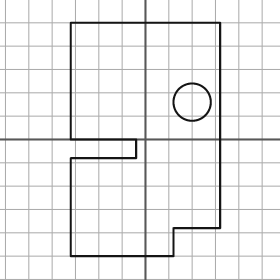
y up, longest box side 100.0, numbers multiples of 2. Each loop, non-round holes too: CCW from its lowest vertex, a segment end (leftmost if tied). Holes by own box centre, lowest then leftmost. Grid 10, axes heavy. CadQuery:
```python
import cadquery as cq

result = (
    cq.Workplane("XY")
    .moveTo(-32.0, -50.0)
    .lineTo(12.0, -50.0)
    .lineTo(12.0, -38.0)
    .lineTo(32.0, -38.0)
    .lineTo(32.0, 50.0)
    .lineTo(-32.0, 50.0)
    .lineTo(-32.0, 0.0)
    .lineTo(-4.0, 0.0)
    .lineTo(-4.0, -8.0)
    .lineTo(-32.0, -8.0)
    .close()
    .moveTo(20.0, 16.0)
    .circle(8.0)
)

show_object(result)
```